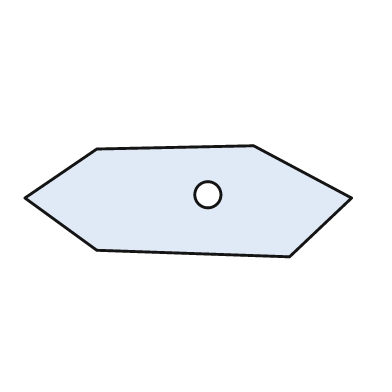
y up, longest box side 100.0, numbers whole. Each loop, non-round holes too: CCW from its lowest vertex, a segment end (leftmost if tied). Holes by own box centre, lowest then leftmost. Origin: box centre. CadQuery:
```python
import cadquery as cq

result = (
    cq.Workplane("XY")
    .moveTo(31.0, -17.0)
    .lineTo(50.0, 1.0)
    .lineTo(20.0, 17.0)
    .lineTo(-28.0, 16.0)
    .lineTo(-50.0, 1.0)
    .lineTo(-28.0, -15.0)
    .close()
    .moveTo(6.0, 2.0)
    .circle(4.0)
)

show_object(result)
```